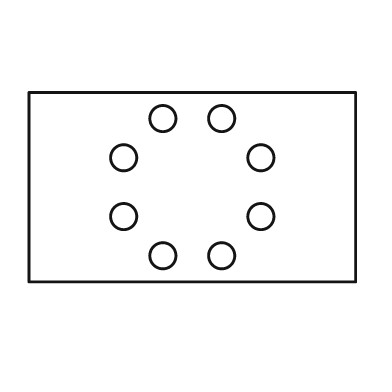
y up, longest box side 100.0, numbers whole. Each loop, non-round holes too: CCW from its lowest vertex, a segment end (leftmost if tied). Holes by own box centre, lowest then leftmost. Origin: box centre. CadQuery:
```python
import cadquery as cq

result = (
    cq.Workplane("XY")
    .moveTo(-50.0, -29.0)
    .lineTo(50.0, -29.0)
    .lineTo(50.0, 29.0)
    .lineTo(-50.0, 29.0)
    .close()
    .moveTo(-9.0, -21.0)
    .circle(4.0)
    .moveTo(9.0, -21.0)
    .circle(4.0)
    .moveTo(-21.0, -9.0)
    .circle(4.0)
    .moveTo(21.0, -9.0)
    .circle(4.0)
    .moveTo(-21.0, 9.0)
    .circle(4.0)
    .moveTo(21.0, 9.0)
    .circle(4.0)
    .moveTo(-9.0, 21.0)
    .circle(4.0)
    .moveTo(9.0, 21.0)
    .circle(4.0)
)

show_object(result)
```